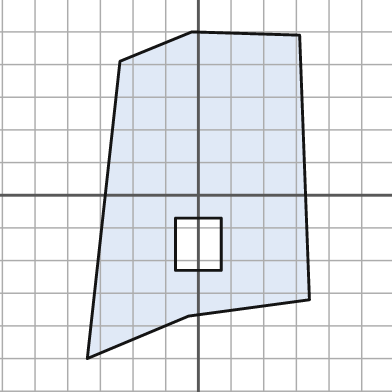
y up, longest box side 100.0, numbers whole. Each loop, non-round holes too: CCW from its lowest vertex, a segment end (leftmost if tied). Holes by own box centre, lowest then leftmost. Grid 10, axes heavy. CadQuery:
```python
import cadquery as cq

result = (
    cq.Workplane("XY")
    .moveTo(-34.0, -50.0)
    .lineTo(-3.0, -37.0)
    .lineTo(34.0, -32.0)
    .lineTo(31.0, 49.0)
    .lineTo(-2.0, 50.0)
    .lineTo(-24.0, 41.0)
    .close()
    .moveTo(-7.0, -23.0)
    .lineTo(7.0, -23.0)
    .lineTo(7.0, -7.0)
    .lineTo(-7.0, -7.0)
    .close()
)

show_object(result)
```